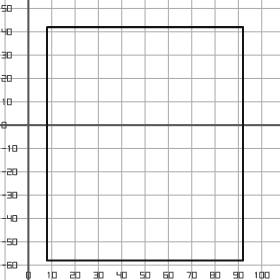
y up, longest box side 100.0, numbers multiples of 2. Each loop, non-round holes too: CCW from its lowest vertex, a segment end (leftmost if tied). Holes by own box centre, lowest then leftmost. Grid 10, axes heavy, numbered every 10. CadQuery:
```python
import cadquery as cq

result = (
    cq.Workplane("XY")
    .moveTo(8.0, -58.0)
    .lineTo(92.0, -58.0)
    .lineTo(92.0, 42.0)
    .lineTo(8.0, 42.0)
    .close()
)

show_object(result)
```